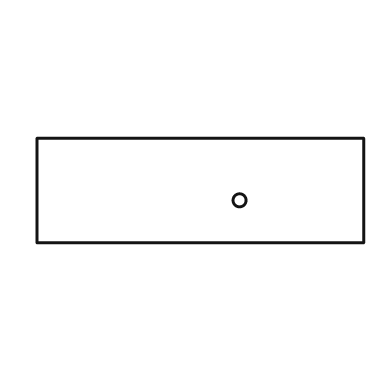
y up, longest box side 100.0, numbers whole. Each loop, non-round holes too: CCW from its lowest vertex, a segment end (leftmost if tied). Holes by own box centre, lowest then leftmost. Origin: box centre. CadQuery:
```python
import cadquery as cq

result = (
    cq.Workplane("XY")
    .moveTo(-50.0, -16.0)
    .lineTo(50.0, -16.0)
    .lineTo(50.0, 16.0)
    .lineTo(-50.0, 16.0)
    .close()
    .moveTo(12.0, -3.0)
    .circle(2.0)
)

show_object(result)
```